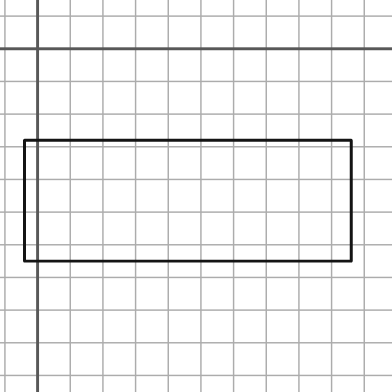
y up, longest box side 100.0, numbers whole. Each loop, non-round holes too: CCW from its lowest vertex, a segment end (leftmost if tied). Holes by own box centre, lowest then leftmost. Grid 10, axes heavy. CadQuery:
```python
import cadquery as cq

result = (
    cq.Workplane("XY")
    .moveTo(-4.0, -65.0)
    .lineTo(96.0, -65.0)
    .lineTo(96.0, -28.0)
    .lineTo(-4.0, -28.0)
    .close()
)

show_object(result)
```